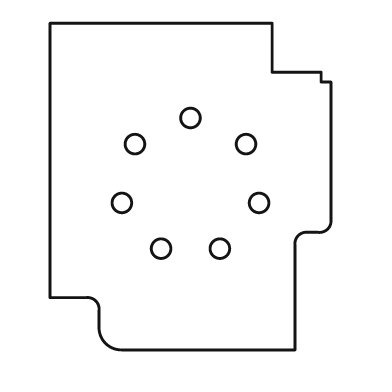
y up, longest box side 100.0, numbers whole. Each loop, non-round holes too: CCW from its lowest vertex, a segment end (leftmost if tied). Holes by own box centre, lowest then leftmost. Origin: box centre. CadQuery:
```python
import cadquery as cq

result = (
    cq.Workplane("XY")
    .moveTo(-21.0, -50.0)
    .lineTo(32.0, -50.0)
    .lineTo(32.0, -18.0)
    .threePointArc((33.0, -15.0), (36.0, -14.0))
    .lineTo(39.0, -14.0)
    .threePointArc((42.0, -13.0), (43.0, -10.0))
    .lineTo(43.0, 32.0)
    .lineTo(40.0, 32.0)
    .lineTo(40.0, 35.0)
    .lineTo(25.0, 35.0)
    .lineTo(25.0, 50.0)
    .lineTo(-43.0, 50.0)
    .lineTo(-43.0, -34.0)
    .lineTo(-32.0, -34.0)
    .threePointArc((-29.0, -35.0), (-28.0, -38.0))
    .lineTo(-28.0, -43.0)
    .threePointArc((-26.0, -48.0), (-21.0, -50.0))
    .close()
    .moveTo(-9.0, -19.0)
    .circle(3.0)
    .moveTo(9.0, -19.0)
    .circle(3.0)
    .moveTo(-21.0, -5.0)
    .circle(3.0)
    .moveTo(21.0, -5.0)
    .circle(3.0)
    .moveTo(-17.0, 13.0)
    .circle(3.0)
    .moveTo(17.0, 13.0)
    .circle(3.0)
    .moveTo(0.0, 21.0)
    .circle(3.0)
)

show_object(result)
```